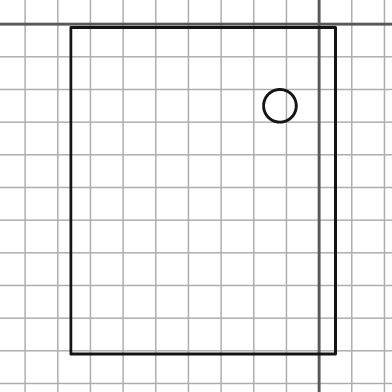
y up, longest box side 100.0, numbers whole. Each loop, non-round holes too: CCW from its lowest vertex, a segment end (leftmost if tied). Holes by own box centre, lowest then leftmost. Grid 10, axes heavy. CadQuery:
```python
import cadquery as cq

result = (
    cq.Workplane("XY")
    .moveTo(-76.0, -101.0)
    .lineTo(5.0, -101.0)
    .lineTo(5.0, -1.0)
    .lineTo(-76.0, -1.0)
    .close()
    .moveTo(-12.0, -25.0)
    .circle(5.0)
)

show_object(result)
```